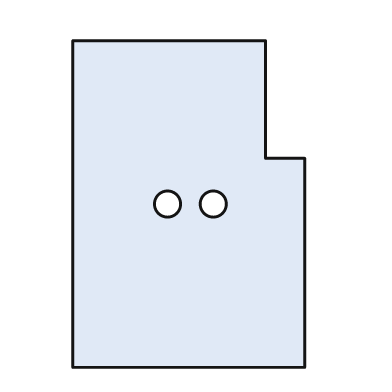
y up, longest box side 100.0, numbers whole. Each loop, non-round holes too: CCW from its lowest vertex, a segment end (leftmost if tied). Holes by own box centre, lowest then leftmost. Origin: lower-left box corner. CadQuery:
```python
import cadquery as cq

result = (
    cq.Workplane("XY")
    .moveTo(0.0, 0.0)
    .lineTo(71.0, 0.0)
    .lineTo(71.0, 64.0)
    .lineTo(59.0, 64.0)
    .lineTo(59.0, 100.0)
    .lineTo(0.0, 100.0)
    .close()
    .moveTo(29.0, 50.0)
    .circle(4.0)
    .moveTo(43.0, 50.0)
    .circle(4.0)
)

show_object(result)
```